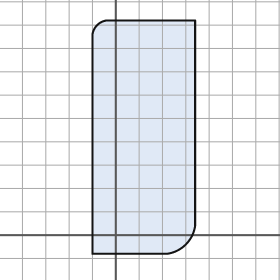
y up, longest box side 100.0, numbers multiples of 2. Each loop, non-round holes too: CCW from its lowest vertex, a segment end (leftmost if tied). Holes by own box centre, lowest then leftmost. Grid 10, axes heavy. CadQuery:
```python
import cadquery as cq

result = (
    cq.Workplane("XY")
    .moveTo(-10.0, -8.0)
    .lineTo(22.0, -8.0)
    .threePointArc((30.0, -4.0), (34.0, 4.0))
    .lineTo(34.0, 92.0)
    .lineTo(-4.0, 92.0)
    .threePointArc((-8.0, 90.0), (-10.0, 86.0))
    .close()
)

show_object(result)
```